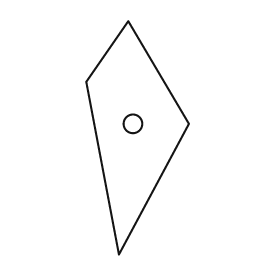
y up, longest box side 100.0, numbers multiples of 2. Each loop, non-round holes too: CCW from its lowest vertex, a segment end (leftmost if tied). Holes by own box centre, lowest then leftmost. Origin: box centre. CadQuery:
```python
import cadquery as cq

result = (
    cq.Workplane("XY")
    .moveTo(-8.0, -50.0)
    .lineTo(22.0, 6.0)
    .lineTo(-4.0, 50.0)
    .lineTo(-22.0, 24.0)
    .close()
    .moveTo(-2.0, 6.0)
    .circle(4.0)
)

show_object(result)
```